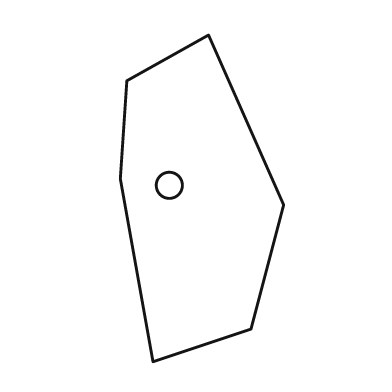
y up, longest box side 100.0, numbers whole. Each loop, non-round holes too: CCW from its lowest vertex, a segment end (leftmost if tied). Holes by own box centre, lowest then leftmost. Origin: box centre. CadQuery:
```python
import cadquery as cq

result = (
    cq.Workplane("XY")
    .moveTo(-15.0, -50.0)
    .lineTo(15.0, -40.0)
    .lineTo(25.0, -2.0)
    .lineTo(2.0, 50.0)
    .lineTo(-23.0, 36.0)
    .lineTo(-25.0, 6.0)
    .close()
    .moveTo(-10.0, 4.0)
    .circle(4.0)
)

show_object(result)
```